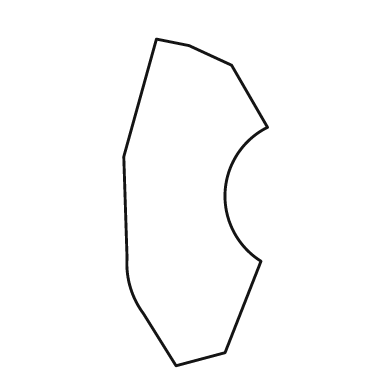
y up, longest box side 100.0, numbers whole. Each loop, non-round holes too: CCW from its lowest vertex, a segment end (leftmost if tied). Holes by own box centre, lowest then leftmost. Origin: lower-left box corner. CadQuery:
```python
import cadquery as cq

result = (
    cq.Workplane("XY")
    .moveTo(16.0, 0.0)
    .lineTo(31.0, 4.0)
    .lineTo(42.0, 32.0)
    .threePointArc((31.0, 53.0), (44.0, 73.0))
    .lineTo(33.0, 92.0)
    .lineTo(20.0, 98.0)
    .lineTo(10.0, 100.0)
    .lineTo(0.0, 64.0)
    .lineTo(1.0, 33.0)
    .threePointArc((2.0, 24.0), (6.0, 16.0))
    .close()
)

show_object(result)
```